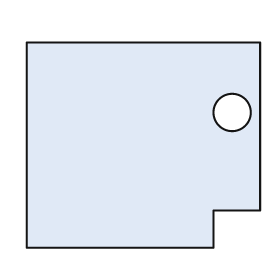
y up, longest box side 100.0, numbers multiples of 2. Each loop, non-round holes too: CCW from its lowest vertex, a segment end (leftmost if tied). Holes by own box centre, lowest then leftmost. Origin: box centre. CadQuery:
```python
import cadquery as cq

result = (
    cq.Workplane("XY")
    .moveTo(-50.0, -44.0)
    .lineTo(30.0, -44.0)
    .lineTo(30.0, -28.0)
    .lineTo(50.0, -28.0)
    .lineTo(50.0, 44.0)
    .lineTo(-50.0, 44.0)
    .close()
    .moveTo(38.0, 14.0)
    .circle(8.0)
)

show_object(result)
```